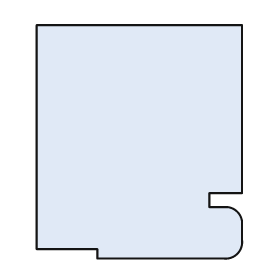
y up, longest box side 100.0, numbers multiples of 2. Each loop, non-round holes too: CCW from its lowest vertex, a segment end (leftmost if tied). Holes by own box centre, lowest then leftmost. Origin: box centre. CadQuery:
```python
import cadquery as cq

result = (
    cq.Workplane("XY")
    .moveTo(-18.0, -50.0)
    .lineTo(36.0, -50.0)
    .threePointArc((42.0, -48.0), (44.0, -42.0))
    .lineTo(44.0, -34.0)
    .threePointArc((42.0, -30.0), (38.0, -28.0))
    .lineTo(30.0, -28.0)
    .lineTo(30.0, -22.0)
    .lineTo(44.0, -22.0)
    .lineTo(44.0, 50.0)
    .lineTo(-44.0, 50.0)
    .lineTo(-44.0, -46.0)
    .lineTo(-18.0, -46.0)
    .close()
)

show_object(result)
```